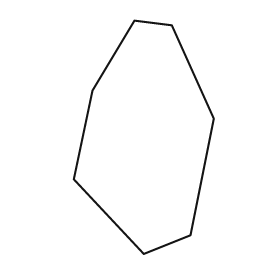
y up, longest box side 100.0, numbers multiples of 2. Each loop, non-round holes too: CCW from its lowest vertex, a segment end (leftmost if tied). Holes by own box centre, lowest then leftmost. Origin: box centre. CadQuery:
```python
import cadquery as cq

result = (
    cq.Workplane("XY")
    .moveTo(0.0, -50.0)
    .lineTo(20.0, -42.0)
    .lineTo(30.0, 8.0)
    .lineTo(12.0, 48.0)
    .lineTo(-4.0, 50.0)
    .lineTo(-22.0, 20.0)
    .lineTo(-30.0, -18.0)
    .close()
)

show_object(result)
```